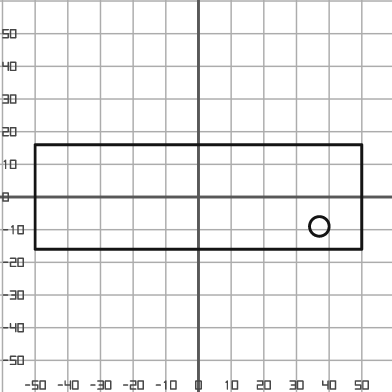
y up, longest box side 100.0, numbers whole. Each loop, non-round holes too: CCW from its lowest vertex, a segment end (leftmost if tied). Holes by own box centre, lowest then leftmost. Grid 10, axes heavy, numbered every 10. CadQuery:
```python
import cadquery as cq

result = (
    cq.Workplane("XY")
    .moveTo(-50.0, -16.0)
    .lineTo(50.0, -16.0)
    .lineTo(50.0, 16.0)
    .lineTo(-50.0, 16.0)
    .close()
    .moveTo(37.0, -9.0)
    .circle(3.0)
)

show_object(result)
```